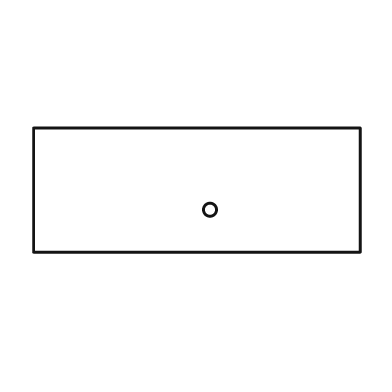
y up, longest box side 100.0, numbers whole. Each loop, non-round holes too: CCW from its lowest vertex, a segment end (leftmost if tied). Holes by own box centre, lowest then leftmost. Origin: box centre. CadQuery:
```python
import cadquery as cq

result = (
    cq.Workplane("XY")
    .moveTo(-50.0, -19.0)
    .lineTo(50.0, -19.0)
    .lineTo(50.0, 19.0)
    .lineTo(-50.0, 19.0)
    .close()
    .moveTo(4.0, -6.0)
    .circle(2.0)
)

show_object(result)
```